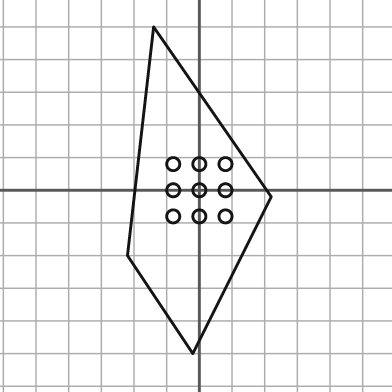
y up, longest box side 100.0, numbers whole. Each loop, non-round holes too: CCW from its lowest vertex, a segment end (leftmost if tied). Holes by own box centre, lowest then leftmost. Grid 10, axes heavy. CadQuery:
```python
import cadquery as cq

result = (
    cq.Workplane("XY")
    .moveTo(-2.0, -50.0)
    .lineTo(22.0, -2.0)
    .lineTo(-14.0, 50.0)
    .lineTo(-22.0, -20.0)
    .close()
    .moveTo(-8.0, -8.0)
    .circle(2.0)
    .moveTo(0.0, -8.0)
    .circle(2.0)
    .moveTo(8.0, -8.0)
    .circle(2.0)
    .moveTo(-8.0, 0.0)
    .circle(2.0)
    .moveTo(0.0, 0.0)
    .circle(2.0)
    .moveTo(8.0, 0.0)
    .circle(2.0)
    .moveTo(-8.0, 8.0)
    .circle(2.0)
    .moveTo(0.0, 8.0)
    .circle(2.0)
    .moveTo(8.0, 8.0)
    .circle(2.0)
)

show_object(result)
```